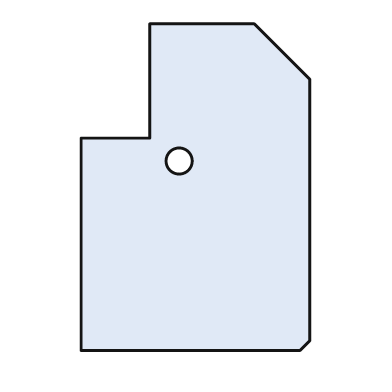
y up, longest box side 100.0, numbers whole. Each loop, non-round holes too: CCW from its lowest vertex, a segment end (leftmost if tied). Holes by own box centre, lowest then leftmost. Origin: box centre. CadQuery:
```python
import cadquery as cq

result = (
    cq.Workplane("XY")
    .moveTo(-35.0, -50.0)
    .lineTo(32.0, -50.0)
    .lineTo(35.0, -47.0)
    .lineTo(35.0, 33.0)
    .lineTo(18.0, 50.0)
    .lineTo(-14.0, 50.0)
    .lineTo(-14.0, 15.0)
    .lineTo(-35.0, 15.0)
    .close()
    .moveTo(-5.0, 8.0)
    .circle(4.0)
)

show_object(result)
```